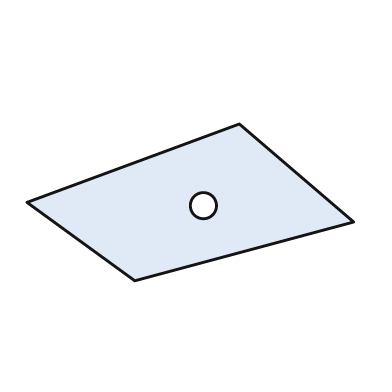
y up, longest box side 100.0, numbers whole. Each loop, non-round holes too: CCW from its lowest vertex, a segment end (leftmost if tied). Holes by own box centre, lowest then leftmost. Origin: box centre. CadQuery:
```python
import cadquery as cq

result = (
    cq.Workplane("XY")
    .moveTo(-17.0, -24.0)
    .lineTo(50.0, -6.0)
    .lineTo(15.0, 24.0)
    .lineTo(-50.0, 0.0)
    .close()
    .moveTo(4.0, -1.0)
    .circle(4.0)
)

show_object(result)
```